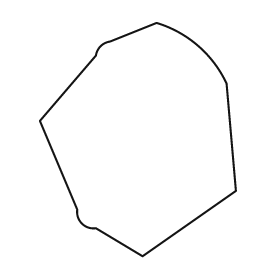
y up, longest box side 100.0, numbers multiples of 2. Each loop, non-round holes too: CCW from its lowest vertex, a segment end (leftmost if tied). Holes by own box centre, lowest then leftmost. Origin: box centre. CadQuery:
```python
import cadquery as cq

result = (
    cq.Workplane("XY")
    .moveTo(2.0, -50.0)
    .lineTo(42.0, -22.0)
    .lineTo(38.0, 24.0)
    .threePointArc((26.0, 40.0), (8.0, 50.0))
    .lineTo(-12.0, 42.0)
    .threePointArc((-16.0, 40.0), (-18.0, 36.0))
    .lineTo(-42.0, 8.0)
    .lineTo(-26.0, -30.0)
    .threePointArc((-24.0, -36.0), (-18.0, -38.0))
    .close()
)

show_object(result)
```